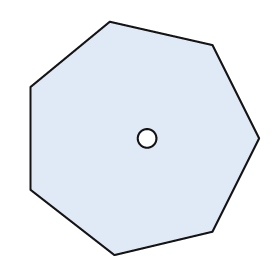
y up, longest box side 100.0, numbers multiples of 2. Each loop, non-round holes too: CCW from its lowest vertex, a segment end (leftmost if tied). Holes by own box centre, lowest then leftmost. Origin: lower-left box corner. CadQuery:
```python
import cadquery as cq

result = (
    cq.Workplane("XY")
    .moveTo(36.0, 0.0)
    .lineTo(78.0, 10.0)
    .lineTo(98.0, 50.0)
    .lineTo(78.0, 90.0)
    .lineTo(34.0, 100.0)
    .lineTo(0.0, 72.0)
    .lineTo(0.0, 28.0)
    .close()
    .moveTo(50.0, 50.0)
    .circle(4.0)
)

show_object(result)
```